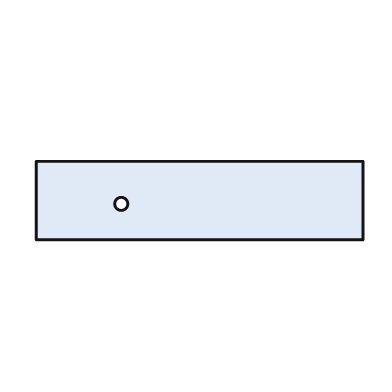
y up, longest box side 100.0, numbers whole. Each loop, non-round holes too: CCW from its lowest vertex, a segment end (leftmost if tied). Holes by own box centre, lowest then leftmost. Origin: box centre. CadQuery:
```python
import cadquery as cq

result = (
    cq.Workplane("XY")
    .moveTo(-50.0, -12.0)
    .lineTo(50.0, -12.0)
    .lineTo(50.0, 12.0)
    .lineTo(-50.0, 12.0)
    .close()
    .moveTo(-24.0, -1.0)
    .circle(2.0)
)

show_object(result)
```